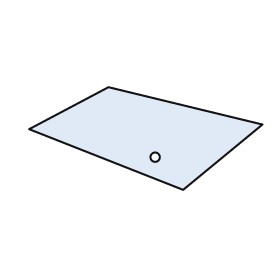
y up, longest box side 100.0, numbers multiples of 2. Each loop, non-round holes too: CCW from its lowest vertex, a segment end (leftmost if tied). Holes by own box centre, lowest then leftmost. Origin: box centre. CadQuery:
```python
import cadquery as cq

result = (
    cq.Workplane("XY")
    .moveTo(16.0, -22.0)
    .lineTo(50.0, 6.0)
    .lineTo(-16.0, 22.0)
    .lineTo(-50.0, 4.0)
    .close()
    .moveTo(4.0, -8.0)
    .circle(2.0)
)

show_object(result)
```